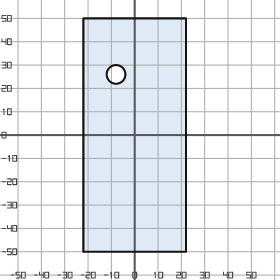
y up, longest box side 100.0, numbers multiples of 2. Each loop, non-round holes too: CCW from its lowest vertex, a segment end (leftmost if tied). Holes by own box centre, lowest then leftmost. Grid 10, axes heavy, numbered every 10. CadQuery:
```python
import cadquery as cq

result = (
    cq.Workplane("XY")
    .moveTo(-22.0, -50.0)
    .lineTo(22.0, -50.0)
    .lineTo(22.0, 50.0)
    .lineTo(-22.0, 50.0)
    .close()
    .moveTo(-8.0, 26.0)
    .circle(4.0)
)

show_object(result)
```